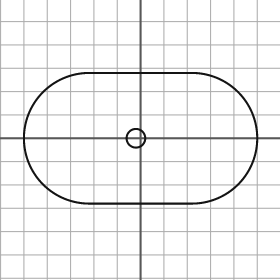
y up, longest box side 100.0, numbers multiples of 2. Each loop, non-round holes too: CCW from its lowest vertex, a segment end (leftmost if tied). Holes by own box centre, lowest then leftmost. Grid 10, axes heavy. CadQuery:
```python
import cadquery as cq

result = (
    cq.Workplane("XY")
    .moveTo(-22.0, -28.0)
    .lineTo(22.0, -28.0)
    .threePointArc((50.0, 0.0), (22.0, 28.0))
    .lineTo(-22.0, 28.0)
    .threePointArc((-50.0, 0.0), (-22.0, -28.0))
    .close()
    .moveTo(-2.0, 0.0)
    .circle(4.0)
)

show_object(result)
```